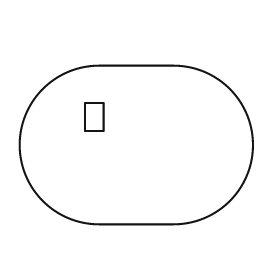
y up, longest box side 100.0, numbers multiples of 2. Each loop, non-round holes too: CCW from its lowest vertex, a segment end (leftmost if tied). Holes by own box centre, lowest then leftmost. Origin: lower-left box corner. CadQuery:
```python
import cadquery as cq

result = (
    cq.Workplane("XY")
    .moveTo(34.0, 0.0)
    .lineTo(66.0, 0.0)
    .threePointArc((100.0, 34.0), (66.0, 68.0))
    .lineTo(34.0, 68.0)
    .threePointArc((0.0, 34.0), (34.0, 0.0))
    .close()
    .moveTo(28.0, 40.0)
    .lineTo(36.0, 40.0)
    .lineTo(36.0, 52.0)
    .lineTo(28.0, 52.0)
    .close()
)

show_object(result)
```